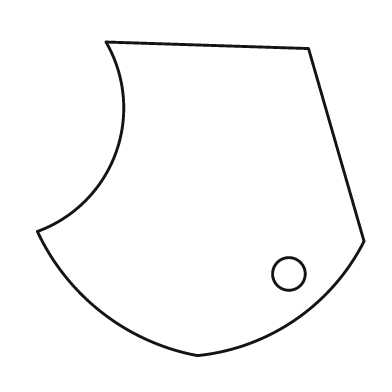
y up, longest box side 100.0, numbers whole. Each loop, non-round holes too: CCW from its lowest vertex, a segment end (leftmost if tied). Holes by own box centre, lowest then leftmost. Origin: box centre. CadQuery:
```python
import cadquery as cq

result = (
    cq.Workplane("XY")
    .moveTo(-1.0, -48.0)
    .threePointArc((29.0, -37.0), (50.0, -13.0))
    .lineTo(33.0, 46.0)
    .lineTo(-29.0, 48.0)
    .threePointArc((-26.0, 14.0), (-50.0, -10.0))
    .threePointArc((-30.0, -35.0), (-1.0, -48.0))
    .close()
    .moveTo(27.0, -23.0)
    .circle(5.0)
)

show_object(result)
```